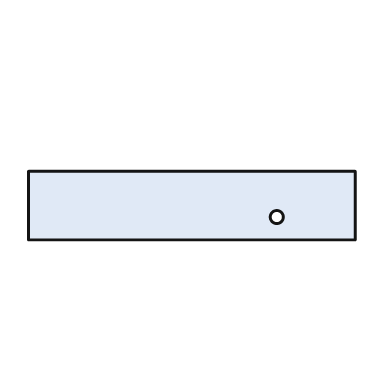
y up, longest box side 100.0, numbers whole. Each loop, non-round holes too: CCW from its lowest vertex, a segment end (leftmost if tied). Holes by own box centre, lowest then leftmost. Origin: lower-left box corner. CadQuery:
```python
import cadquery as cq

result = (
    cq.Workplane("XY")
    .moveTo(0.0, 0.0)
    .lineTo(100.0, 0.0)
    .lineTo(100.0, 21.0)
    .lineTo(0.0, 21.0)
    .close()
    .moveTo(76.0, 7.0)
    .circle(2.0)
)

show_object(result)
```